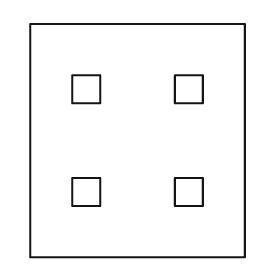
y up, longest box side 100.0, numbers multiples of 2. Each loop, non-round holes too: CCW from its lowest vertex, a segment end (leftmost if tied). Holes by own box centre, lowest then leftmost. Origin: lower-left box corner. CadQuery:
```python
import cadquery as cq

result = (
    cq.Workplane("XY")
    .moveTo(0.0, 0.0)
    .lineTo(92.0, 0.0)
    .lineTo(92.0, 100.0)
    .lineTo(0.0, 100.0)
    .close()
    .moveTo(18.0, 22.0)
    .lineTo(30.0, 22.0)
    .lineTo(30.0, 34.0)
    .lineTo(18.0, 34.0)
    .close()
    .moveTo(62.0, 22.0)
    .lineTo(74.0, 22.0)
    .lineTo(74.0, 34.0)
    .lineTo(62.0, 34.0)
    .close()
    .moveTo(18.0, 66.0)
    .lineTo(30.0, 66.0)
    .lineTo(30.0, 78.0)
    .lineTo(18.0, 78.0)
    .close()
    .moveTo(62.0, 66.0)
    .lineTo(74.0, 66.0)
    .lineTo(74.0, 78.0)
    .lineTo(62.0, 78.0)
    .close()
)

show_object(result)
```